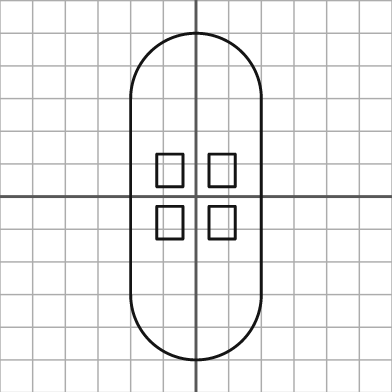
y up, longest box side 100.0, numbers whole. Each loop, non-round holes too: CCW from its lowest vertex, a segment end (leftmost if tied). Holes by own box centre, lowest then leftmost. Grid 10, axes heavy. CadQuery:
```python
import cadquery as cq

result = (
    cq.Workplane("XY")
    .moveTo(-20.0, -30.0)
    .threePointArc((0.0, -50.0), (20.0, -30.0))
    .lineTo(20.0, 30.0)
    .threePointArc((0.0, 50.0), (-20.0, 30.0))
    .close()
    .moveTo(-12.0, -13.0)
    .lineTo(-4.0, -13.0)
    .lineTo(-4.0, -3.0)
    .lineTo(-12.0, -3.0)
    .close()
    .moveTo(4.0, -13.0)
    .lineTo(12.0, -13.0)
    .lineTo(12.0, -3.0)
    .lineTo(4.0, -3.0)
    .close()
    .moveTo(-12.0, 3.0)
    .lineTo(-4.0, 3.0)
    .lineTo(-4.0, 13.0)
    .lineTo(-12.0, 13.0)
    .close()
    .moveTo(4.0, 3.0)
    .lineTo(12.0, 3.0)
    .lineTo(12.0, 13.0)
    .lineTo(4.0, 13.0)
    .close()
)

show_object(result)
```